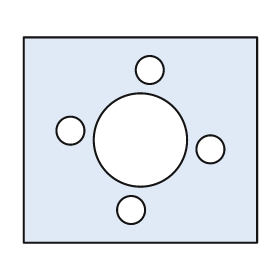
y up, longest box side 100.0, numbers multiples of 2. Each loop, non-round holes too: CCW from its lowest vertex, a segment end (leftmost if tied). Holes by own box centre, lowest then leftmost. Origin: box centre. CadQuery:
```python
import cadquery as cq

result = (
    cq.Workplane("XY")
    .moveTo(-50.0, -44.0)
    .lineTo(50.0, -44.0)
    .lineTo(50.0, 44.0)
    .lineTo(-50.0, 44.0)
    .close()
    .moveTo(-4.0, -30.0)
    .circle(6.0)
    .moveTo(30.0, -4.0)
    .circle(6.0)
    .moveTo(0.0, 0.0)
    .circle(20.0)
    .moveTo(-30.0, 4.0)
    .circle(6.0)
    .moveTo(4.0, 30.0)
    .circle(6.0)
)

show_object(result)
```